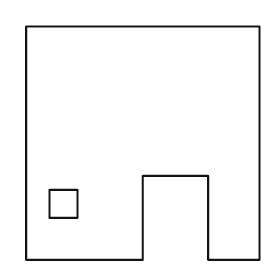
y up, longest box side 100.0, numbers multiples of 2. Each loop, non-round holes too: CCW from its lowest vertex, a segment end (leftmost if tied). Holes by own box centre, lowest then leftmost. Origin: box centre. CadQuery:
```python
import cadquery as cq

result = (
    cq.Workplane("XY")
    .moveTo(-50.0, -50.0)
    .lineTo(0.0, -50.0)
    .lineTo(0.0, -14.0)
    .lineTo(28.0, -14.0)
    .lineTo(28.0, -50.0)
    .lineTo(50.0, -50.0)
    .lineTo(50.0, 50.0)
    .lineTo(-50.0, 50.0)
    .close()
    .moveTo(-40.0, -32.0)
    .lineTo(-28.0, -32.0)
    .lineTo(-28.0, -20.0)
    .lineTo(-40.0, -20.0)
    .close()
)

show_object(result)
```